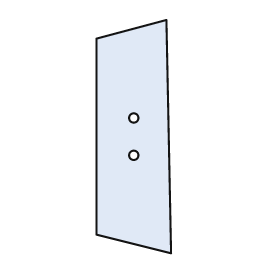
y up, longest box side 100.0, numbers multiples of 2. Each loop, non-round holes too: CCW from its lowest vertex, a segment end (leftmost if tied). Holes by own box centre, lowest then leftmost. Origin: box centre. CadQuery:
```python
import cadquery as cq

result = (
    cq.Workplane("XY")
    .moveTo(16.0, -50.0)
    .lineTo(14.0, 50.0)
    .lineTo(-16.0, 42.0)
    .lineTo(-16.0, -42.0)
    .close()
    .moveTo(0.0, -8.0)
    .circle(2.0)
    .moveTo(0.0, 8.0)
    .circle(2.0)
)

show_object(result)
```